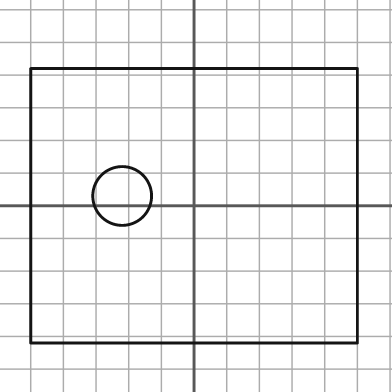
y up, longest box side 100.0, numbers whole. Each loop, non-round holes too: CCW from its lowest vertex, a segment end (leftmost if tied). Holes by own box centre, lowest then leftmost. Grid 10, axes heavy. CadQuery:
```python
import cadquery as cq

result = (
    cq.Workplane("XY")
    .moveTo(-50.0, -42.0)
    .lineTo(50.0, -42.0)
    .lineTo(50.0, 42.0)
    .lineTo(-50.0, 42.0)
    .close()
    .moveTo(-22.0, 3.0)
    .circle(9.0)
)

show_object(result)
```